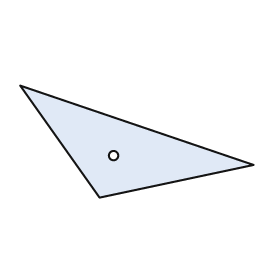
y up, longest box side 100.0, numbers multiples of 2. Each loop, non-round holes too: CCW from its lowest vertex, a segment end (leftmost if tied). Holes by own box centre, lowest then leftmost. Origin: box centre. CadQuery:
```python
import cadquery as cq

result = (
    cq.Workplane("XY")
    .moveTo(-16.0, -24.0)
    .lineTo(50.0, -10.0)
    .lineTo(-50.0, 24.0)
    .close()
    .moveTo(-10.0, -6.0)
    .circle(2.0)
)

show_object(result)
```